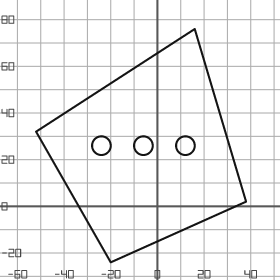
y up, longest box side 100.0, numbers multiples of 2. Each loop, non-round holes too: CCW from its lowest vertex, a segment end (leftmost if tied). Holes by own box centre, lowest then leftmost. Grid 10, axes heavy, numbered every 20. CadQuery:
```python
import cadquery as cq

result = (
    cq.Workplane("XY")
    .moveTo(-20.0, -24.0)
    .lineTo(38.0, 2.0)
    .lineTo(16.0, 76.0)
    .lineTo(-52.0, 32.0)
    .close()
    .moveTo(-24.0, 26.0)
    .circle(4.0)
    .moveTo(-6.0, 26.0)
    .circle(4.0)
    .moveTo(12.0, 26.0)
    .circle(4.0)
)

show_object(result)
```